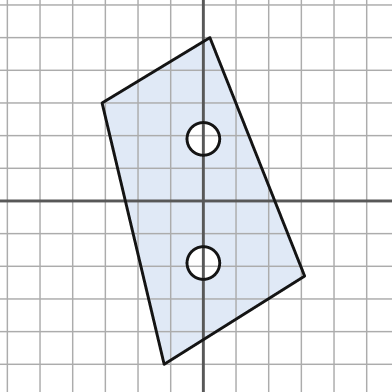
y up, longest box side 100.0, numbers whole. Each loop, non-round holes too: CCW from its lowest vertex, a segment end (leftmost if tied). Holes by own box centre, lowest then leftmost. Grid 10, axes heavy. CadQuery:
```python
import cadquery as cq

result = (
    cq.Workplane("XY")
    .moveTo(-12.0, -50.0)
    .lineTo(31.0, -23.0)
    .lineTo(2.0, 50.0)
    .lineTo(-31.0, 30.0)
    .close()
    .moveTo(0.0, -19.0)
    .circle(5.0)
    .moveTo(0.0, 19.0)
    .circle(5.0)
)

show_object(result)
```